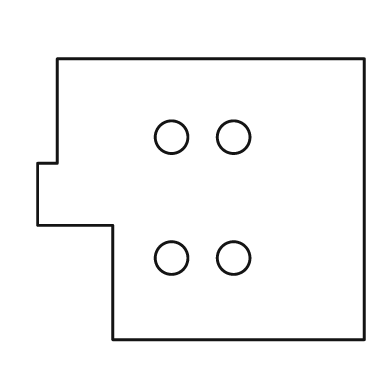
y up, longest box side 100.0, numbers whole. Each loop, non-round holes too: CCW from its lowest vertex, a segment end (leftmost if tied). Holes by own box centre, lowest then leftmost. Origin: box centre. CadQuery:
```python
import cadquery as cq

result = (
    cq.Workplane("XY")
    .moveTo(-27.0, -43.0)
    .lineTo(50.0, -43.0)
    .lineTo(50.0, 43.0)
    .lineTo(-44.0, 43.0)
    .lineTo(-44.0, 11.0)
    .lineTo(-50.0, 11.0)
    .lineTo(-50.0, -8.0)
    .lineTo(-27.0, -8.0)
    .close()
    .moveTo(-9.0, -18.0)
    .circle(5.0)
    .moveTo(10.0, -18.0)
    .circle(5.0)
    .moveTo(-9.0, 19.0)
    .circle(5.0)
    .moveTo(10.0, 19.0)
    .circle(5.0)
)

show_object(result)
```